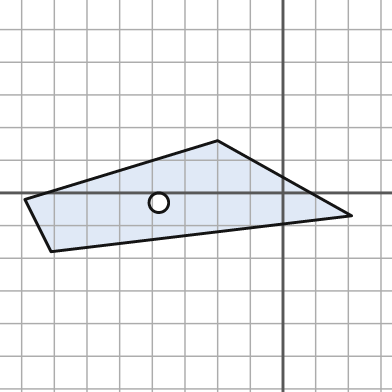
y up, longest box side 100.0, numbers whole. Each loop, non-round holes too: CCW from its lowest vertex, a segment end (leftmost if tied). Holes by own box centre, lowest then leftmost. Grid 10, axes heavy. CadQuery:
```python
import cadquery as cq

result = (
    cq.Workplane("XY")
    .moveTo(-71.0, -18.0)
    .lineTo(21.0, -7.0)
    .lineTo(-20.0, 16.0)
    .lineTo(-79.0, -2.0)
    .close()
    .moveTo(-38.0, -3.0)
    .circle(3.0)
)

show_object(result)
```